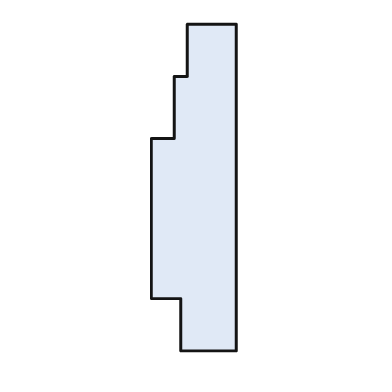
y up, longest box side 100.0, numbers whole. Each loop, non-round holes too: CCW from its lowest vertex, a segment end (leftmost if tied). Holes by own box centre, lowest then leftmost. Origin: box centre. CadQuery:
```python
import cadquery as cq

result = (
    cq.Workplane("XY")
    .moveTo(-4.0, -50.0)
    .lineTo(13.0, -50.0)
    .lineTo(13.0, 50.0)
    .lineTo(-2.0, 50.0)
    .lineTo(-2.0, 34.0)
    .lineTo(-6.0, 34.0)
    .lineTo(-6.0, 15.0)
    .lineTo(-13.0, 15.0)
    .lineTo(-13.0, -34.0)
    .lineTo(-4.0, -34.0)
    .close()
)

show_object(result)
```